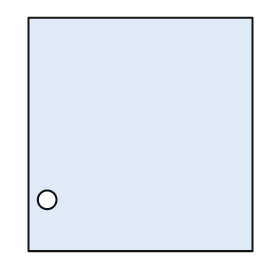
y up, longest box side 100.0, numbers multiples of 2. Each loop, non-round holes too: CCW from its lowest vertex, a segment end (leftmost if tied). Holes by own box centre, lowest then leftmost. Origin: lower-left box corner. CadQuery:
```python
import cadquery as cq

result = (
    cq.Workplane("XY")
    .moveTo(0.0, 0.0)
    .lineTo(96.0, 0.0)
    .lineTo(96.0, 100.0)
    .lineTo(0.0, 100.0)
    .close()
    .moveTo(8.0, 22.0)
    .circle(4.0)
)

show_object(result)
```